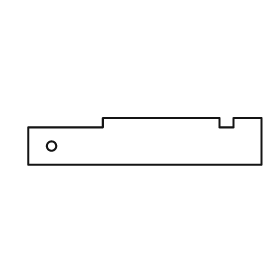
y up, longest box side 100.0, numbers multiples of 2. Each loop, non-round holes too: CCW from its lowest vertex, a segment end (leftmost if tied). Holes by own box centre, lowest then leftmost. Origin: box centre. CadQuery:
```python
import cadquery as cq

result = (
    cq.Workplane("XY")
    .moveTo(-50.0, -10.0)
    .lineTo(50.0, -10.0)
    .lineTo(50.0, 10.0)
    .lineTo(38.0, 10.0)
    .lineTo(38.0, 6.0)
    .lineTo(32.0, 6.0)
    .lineTo(32.0, 10.0)
    .lineTo(-18.0, 10.0)
    .lineTo(-18.0, 6.0)
    .lineTo(-50.0, 6.0)
    .close()
    .moveTo(-40.0, -2.0)
    .circle(2.0)
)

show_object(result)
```